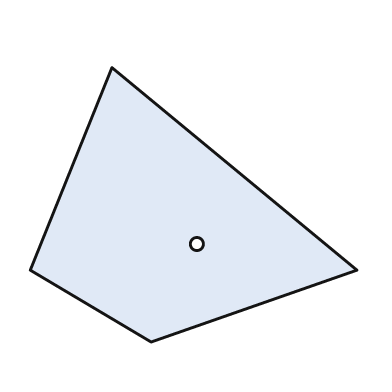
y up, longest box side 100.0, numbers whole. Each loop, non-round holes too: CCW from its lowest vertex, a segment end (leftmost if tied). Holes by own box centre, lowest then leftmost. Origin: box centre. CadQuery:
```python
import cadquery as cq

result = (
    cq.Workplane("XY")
    .moveTo(-13.0, -42.0)
    .lineTo(50.0, -20.0)
    .lineTo(-25.0, 42.0)
    .lineTo(-50.0, -20.0)
    .close()
    .moveTo(1.0, -12.0)
    .circle(2.0)
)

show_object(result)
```